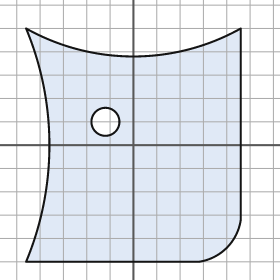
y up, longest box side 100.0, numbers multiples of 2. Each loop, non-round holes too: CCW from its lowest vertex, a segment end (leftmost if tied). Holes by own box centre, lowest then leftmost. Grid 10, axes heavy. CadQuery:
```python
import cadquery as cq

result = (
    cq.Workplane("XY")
    .moveTo(-46.0, -50.0)
    .lineTo(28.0, -50.0)
    .threePointArc((40.0, -44.0), (46.0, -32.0))
    .lineTo(46.0, 50.0)
    .threePointArc((0.0, 38.0), (-46.0, 50.0))
    .threePointArc((-36.0, 0.0), (-46.0, -50.0))
    .close()
    .moveTo(-12.0, 10.0)
    .circle(6.0)
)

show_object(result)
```